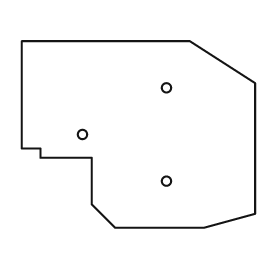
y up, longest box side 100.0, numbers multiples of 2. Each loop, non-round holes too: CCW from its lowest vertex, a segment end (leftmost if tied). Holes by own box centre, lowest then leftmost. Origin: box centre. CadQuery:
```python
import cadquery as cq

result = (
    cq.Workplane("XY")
    .moveTo(-10.0, -40.0)
    .lineTo(28.0, -40.0)
    .lineTo(50.0, -34.0)
    .lineTo(50.0, 22.0)
    .lineTo(22.0, 40.0)
    .lineTo(-50.0, 40.0)
    .lineTo(-50.0, -6.0)
    .lineTo(-42.0, -6.0)
    .lineTo(-42.0, -10.0)
    .lineTo(-20.0, -10.0)
    .lineTo(-20.0, -30.0)
    .close()
    .moveTo(12.0, -20.0)
    .circle(2.0)
    .moveTo(-24.0, 0.0)
    .circle(2.0)
    .moveTo(12.0, 20.0)
    .circle(2.0)
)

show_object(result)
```